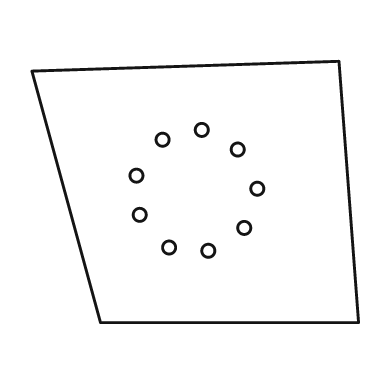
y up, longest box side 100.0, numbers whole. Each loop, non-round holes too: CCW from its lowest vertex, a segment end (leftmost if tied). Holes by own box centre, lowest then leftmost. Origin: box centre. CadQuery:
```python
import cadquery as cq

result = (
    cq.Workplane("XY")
    .moveTo(-29.0, -40.0)
    .lineTo(50.0, -40.0)
    .lineTo(44.0, 40.0)
    .lineTo(-50.0, 37.0)
    .close()
    .moveTo(4.0, -18.0)
    .circle(2.0)
    .moveTo(-8.0, -17.0)
    .circle(2.0)
    .moveTo(15.0, -11.0)
    .circle(2.0)
    .moveTo(-17.0, -7.0)
    .circle(2.0)
    .moveTo(19.0, 1.0)
    .circle(2.0)
    .moveTo(-18.0, 5.0)
    .circle(2.0)
    .moveTo(13.0, 13.0)
    .circle(2.0)
    .moveTo(-10.0, 16.0)
    .circle(2.0)
    .moveTo(2.0, 19.0)
    .circle(2.0)
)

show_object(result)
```